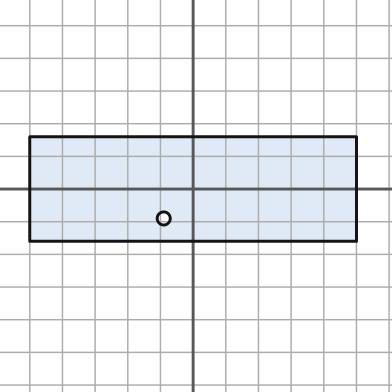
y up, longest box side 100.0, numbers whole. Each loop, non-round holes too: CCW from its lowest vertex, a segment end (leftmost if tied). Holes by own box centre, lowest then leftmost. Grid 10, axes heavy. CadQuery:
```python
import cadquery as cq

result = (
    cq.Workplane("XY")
    .moveTo(-50.0, -16.0)
    .lineTo(50.0, -16.0)
    .lineTo(50.0, 16.0)
    .lineTo(-50.0, 16.0)
    .close()
    .moveTo(-9.0, -9.0)
    .circle(2.0)
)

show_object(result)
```